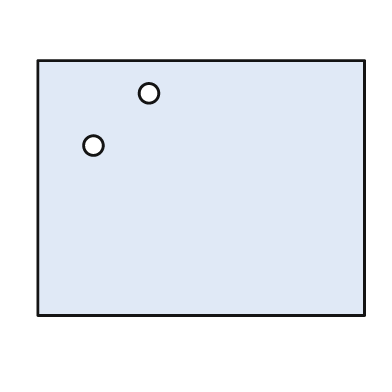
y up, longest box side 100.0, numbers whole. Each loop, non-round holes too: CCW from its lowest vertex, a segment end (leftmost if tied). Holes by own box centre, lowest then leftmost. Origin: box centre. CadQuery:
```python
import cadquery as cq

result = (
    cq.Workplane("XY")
    .moveTo(-50.0, -39.0)
    .lineTo(50.0, -39.0)
    .lineTo(50.0, 39.0)
    .lineTo(-50.0, 39.0)
    .close()
    .moveTo(-33.0, 13.0)
    .circle(3.0)
    .moveTo(-16.0, 29.0)
    .circle(3.0)
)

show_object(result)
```